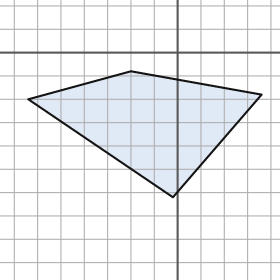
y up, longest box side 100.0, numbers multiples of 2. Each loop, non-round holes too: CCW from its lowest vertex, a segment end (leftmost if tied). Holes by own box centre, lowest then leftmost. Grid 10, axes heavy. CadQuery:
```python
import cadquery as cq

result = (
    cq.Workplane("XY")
    .moveTo(-2.0, -62.0)
    .lineTo(36.0, -18.0)
    .lineTo(-20.0, -8.0)
    .lineTo(-64.0, -20.0)
    .close()
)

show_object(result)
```